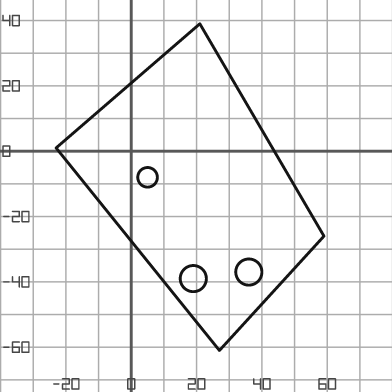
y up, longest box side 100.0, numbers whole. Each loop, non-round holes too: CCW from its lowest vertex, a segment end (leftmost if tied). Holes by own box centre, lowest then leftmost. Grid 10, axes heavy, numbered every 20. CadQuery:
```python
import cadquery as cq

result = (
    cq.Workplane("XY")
    .moveTo(27.0, -61.0)
    .lineTo(59.0, -26.0)
    .lineTo(21.0, 39.0)
    .lineTo(-23.0, 1.0)
    .close()
    .moveTo(19.0, -39.0)
    .circle(4.0)
    .moveTo(36.0, -37.0)
    .circle(4.0)
    .moveTo(5.0, -8.0)
    .circle(3.0)
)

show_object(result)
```